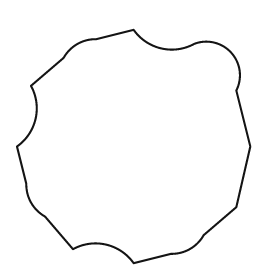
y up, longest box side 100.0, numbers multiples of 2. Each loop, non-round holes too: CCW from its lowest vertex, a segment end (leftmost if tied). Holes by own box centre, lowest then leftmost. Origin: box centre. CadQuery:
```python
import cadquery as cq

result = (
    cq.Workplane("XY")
    .moveTo(0.0, -50.0)
    .lineTo(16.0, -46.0)
    .threePointArc((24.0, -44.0), (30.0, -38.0))
    .lineTo(44.0, -26.0)
    .lineTo(50.0, 0.0)
    .lineTo(44.0, 24.0)
    .threePointArc((42.0, 40.0), (26.0, 44.0))
    .threePointArc((12.0, 42.0), (0.0, 50.0))
    .lineTo(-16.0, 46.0)
    .threePointArc((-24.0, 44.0), (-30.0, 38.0))
    .lineTo(-44.0, 26.0)
    .threePointArc((-42.0, 12.0), (-50.0, 0.0))
    .lineTo(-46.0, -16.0)
    .threePointArc((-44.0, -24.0), (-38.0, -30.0))
    .lineTo(-26.0, -44.0)
    .threePointArc((-12.0, -42.0), (0.0, -50.0))
    .close()
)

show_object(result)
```